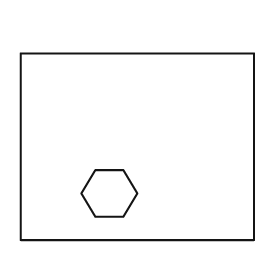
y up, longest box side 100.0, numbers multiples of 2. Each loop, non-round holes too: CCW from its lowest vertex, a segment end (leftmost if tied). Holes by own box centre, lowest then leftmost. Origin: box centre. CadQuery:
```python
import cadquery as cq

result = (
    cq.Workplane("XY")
    .moveTo(-50.0, -40.0)
    .lineTo(50.0, -40.0)
    .lineTo(50.0, 40.0)
    .lineTo(-50.0, 40.0)
    .close()
    .moveTo(-18.0, -30.0)
    .lineTo(-6.0, -30.0)
    .lineTo(0.0, -20.0)
    .lineTo(-6.0, -10.0)
    .lineTo(-18.0, -10.0)
    .lineTo(-24.0, -20.0)
    .close()
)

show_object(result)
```